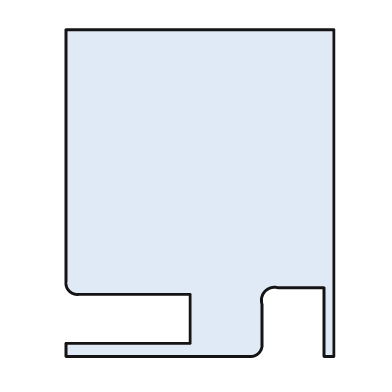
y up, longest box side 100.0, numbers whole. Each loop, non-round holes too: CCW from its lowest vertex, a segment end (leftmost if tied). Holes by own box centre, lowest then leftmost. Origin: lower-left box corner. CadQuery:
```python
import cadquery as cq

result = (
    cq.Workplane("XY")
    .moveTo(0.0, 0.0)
    .lineTo(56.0, 0.0)
    .threePointArc((59.0, 1.0), (60.0, 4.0))
    .lineTo(60.0, 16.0)
    .threePointArc((61.0, 20.0), (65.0, 21.0))
    .lineTo(79.0, 21.0)
    .lineTo(79.0, 0.0)
    .lineTo(82.0, 0.0)
    .lineTo(82.0, 100.0)
    .lineTo(0.0, 100.0)
    .lineTo(0.0, 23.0)
    .threePointArc((1.0, 20.0), (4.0, 19.0))
    .lineTo(38.0, 19.0)
    .lineTo(38.0, 4.0)
    .lineTo(0.0, 4.0)
    .close()
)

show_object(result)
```